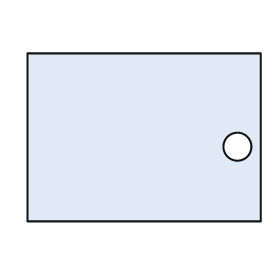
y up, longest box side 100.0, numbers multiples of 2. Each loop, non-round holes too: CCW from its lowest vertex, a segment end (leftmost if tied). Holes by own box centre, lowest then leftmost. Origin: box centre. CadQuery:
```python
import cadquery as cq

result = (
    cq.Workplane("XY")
    .moveTo(-50.0, -36.0)
    .lineTo(50.0, -36.0)
    .lineTo(50.0, 36.0)
    .lineTo(-50.0, 36.0)
    .close()
    .moveTo(40.0, -4.0)
    .circle(6.0)
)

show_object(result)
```